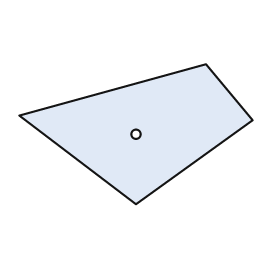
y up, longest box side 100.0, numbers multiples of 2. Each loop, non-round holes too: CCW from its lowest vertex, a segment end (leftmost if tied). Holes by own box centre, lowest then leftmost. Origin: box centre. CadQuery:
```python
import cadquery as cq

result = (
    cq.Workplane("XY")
    .moveTo(0.0, -30.0)
    .lineTo(50.0, 6.0)
    .lineTo(30.0, 30.0)
    .lineTo(-50.0, 8.0)
    .close()
    .moveTo(0.0, 0.0)
    .circle(2.0)
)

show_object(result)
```